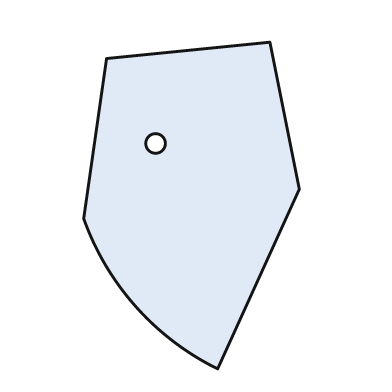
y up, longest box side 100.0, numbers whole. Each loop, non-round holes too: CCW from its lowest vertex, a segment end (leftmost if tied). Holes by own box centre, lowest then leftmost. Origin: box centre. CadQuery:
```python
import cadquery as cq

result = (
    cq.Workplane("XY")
    .moveTo(8.0, -50.0)
    .lineTo(33.0, 5.0)
    .lineTo(24.0, 50.0)
    .lineTo(-26.0, 45.0)
    .lineTo(-33.0, -4.0)
    .threePointArc((-17.0, -31.0), (8.0, -50.0))
    .close()
    .moveTo(-11.0, 19.0)
    .circle(3.0)
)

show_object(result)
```